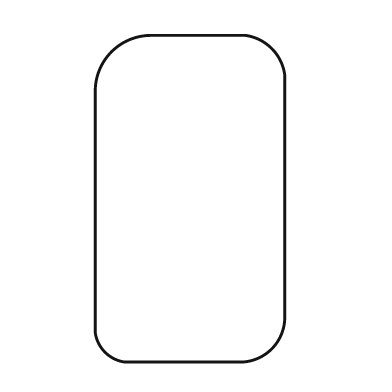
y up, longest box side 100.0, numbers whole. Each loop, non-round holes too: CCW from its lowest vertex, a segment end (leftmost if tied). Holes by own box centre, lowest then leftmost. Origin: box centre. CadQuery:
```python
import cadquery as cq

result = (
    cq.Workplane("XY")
    .moveTo(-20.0, -50.0)
    .lineTo(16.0, -50.0)
    .threePointArc((25.0, -46.0), (29.0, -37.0))
    .lineTo(29.0, 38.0)
    .threePointArc((25.0, 46.0), (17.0, 50.0))
    .lineTo(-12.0, 50.0)
    .threePointArc((-24.0, 45.0), (-29.0, 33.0))
    .lineTo(-29.0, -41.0)
    .threePointArc((-26.0, -47.0), (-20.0, -50.0))
    .close()
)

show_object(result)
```